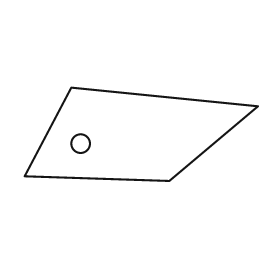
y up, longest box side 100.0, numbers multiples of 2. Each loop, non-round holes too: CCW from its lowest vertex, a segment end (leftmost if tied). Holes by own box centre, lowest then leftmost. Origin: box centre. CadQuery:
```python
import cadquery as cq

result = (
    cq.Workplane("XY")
    .moveTo(12.0, -20.0)
    .lineTo(50.0, 12.0)
    .lineTo(-30.0, 20.0)
    .lineTo(-50.0, -18.0)
    .close()
    .moveTo(-26.0, -4.0)
    .circle(4.0)
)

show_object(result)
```